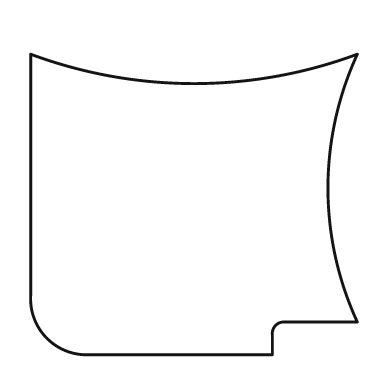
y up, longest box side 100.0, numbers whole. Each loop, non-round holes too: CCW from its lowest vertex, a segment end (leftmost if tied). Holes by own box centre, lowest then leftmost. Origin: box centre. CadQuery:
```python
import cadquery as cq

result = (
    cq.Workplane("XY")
    .moveTo(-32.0, -46.0)
    .lineTo(24.0, -46.0)
    .lineTo(24.0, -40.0)
    .threePointArc((25.0, -37.0), (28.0, -36.0))
    .lineTo(50.0, -36.0)
    .threePointArc((41.0, 5.0), (50.0, 46.0))
    .threePointArc((0.0, 37.0), (-50.0, 46.0))
    .lineTo(-50.0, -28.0)
    .threePointArc((-45.0, -41.0), (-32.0, -46.0))
    .close()
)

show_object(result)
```